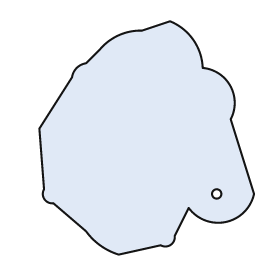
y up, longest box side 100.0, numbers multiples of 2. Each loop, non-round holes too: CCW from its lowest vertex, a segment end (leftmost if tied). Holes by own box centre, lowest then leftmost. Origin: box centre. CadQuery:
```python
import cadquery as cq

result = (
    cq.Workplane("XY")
    .moveTo(-12.0, -50.0)
    .lineTo(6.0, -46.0)
    .threePointArc((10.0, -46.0), (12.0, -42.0))
    .lineTo(18.0, -30.0)
    .threePointArc((34.0, -36.0), (46.0, -24.0))
    .lineTo(36.0, 8.0)
    .threePointArc((36.0, 22.0), (24.0, 30.0))
    .threePointArc((20.0, 42.0), (10.0, 50.0))
    .lineTo(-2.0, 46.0)
    .threePointArc((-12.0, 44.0), (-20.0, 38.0))
    .lineTo(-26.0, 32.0)
    .threePointArc((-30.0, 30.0), (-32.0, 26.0))
    .lineTo(-46.0, 4.0)
    .lineTo(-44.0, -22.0)
    .threePointArc((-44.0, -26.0), (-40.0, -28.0))
    .lineTo(-26.0, -40.0)
    .threePointArc((-20.0, -46.0), (-12.0, -50.0))
    .close()
    .moveTo(30.0, -24.0)
    .circle(2.0)
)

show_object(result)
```